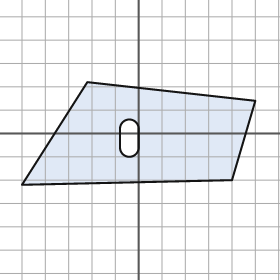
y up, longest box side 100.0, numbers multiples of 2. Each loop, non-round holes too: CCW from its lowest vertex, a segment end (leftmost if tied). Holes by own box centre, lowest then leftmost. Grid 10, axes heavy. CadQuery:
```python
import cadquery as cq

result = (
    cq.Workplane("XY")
    .moveTo(-50.0, -22.0)
    .lineTo(40.0, -20.0)
    .lineTo(50.0, 14.0)
    .lineTo(-22.0, 22.0)
    .close()
    .moveTo(-8.0, -6.0)
    .threePointArc((-4.0, -10.0), (0.0, -6.0))
    .lineTo(0.0, 2.0)
    .threePointArc((-4.0, 6.0), (-8.0, 2.0))
    .close()
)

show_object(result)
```